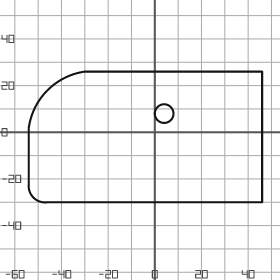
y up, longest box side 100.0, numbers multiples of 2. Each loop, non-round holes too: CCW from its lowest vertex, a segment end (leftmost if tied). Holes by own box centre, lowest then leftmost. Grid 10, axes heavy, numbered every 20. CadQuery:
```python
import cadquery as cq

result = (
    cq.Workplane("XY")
    .moveTo(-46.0, -30.0)
    .lineTo(46.0, -30.0)
    .lineTo(46.0, 26.0)
    .lineTo(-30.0, 26.0)
    .threePointArc((-46.0, 18.0), (-54.0, 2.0))
    .lineTo(-54.0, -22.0)
    .threePointArc((-52.0, -28.0), (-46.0, -30.0))
    .close()
    .moveTo(4.0, 8.0)
    .circle(4.0)
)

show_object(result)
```